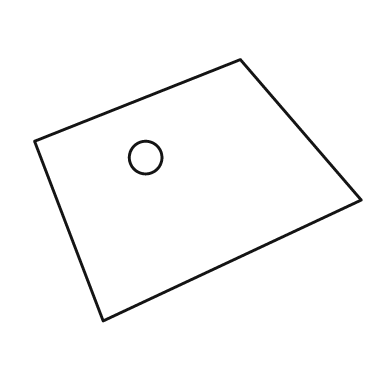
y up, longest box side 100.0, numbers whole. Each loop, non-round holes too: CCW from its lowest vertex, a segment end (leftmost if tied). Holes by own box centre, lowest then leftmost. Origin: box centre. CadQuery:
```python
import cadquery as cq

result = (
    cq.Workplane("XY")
    .moveTo(-29.0, -40.0)
    .lineTo(50.0, -3.0)
    .lineTo(13.0, 40.0)
    .lineTo(-50.0, 15.0)
    .close()
    .moveTo(-16.0, 10.0)
    .circle(5.0)
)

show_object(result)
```